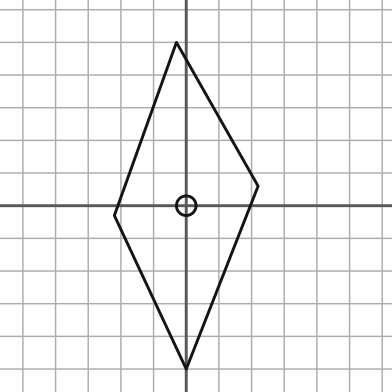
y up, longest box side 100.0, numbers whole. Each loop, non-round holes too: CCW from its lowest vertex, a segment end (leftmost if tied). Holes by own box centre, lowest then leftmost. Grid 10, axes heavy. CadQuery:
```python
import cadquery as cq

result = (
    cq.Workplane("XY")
    .moveTo(0.0, -50.0)
    .lineTo(22.0, 6.0)
    .lineTo(-3.0, 50.0)
    .lineTo(-22.0, -3.0)
    .close()
    .moveTo(0.0, 0.0)
    .circle(3.0)
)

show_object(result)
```